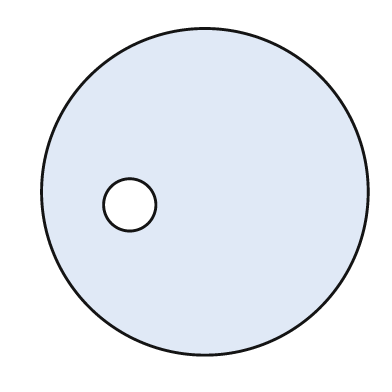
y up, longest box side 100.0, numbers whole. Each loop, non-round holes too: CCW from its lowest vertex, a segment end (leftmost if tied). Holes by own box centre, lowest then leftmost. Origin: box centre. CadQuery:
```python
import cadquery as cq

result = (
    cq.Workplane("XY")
    .moveTo(0.0, 0.0)
    .circle(50.0)
    .moveTo(-23.0, -4.0)
    .circle(8.0)
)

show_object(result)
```